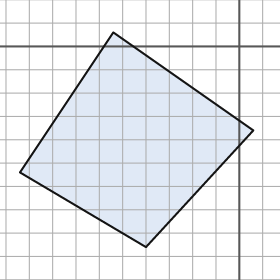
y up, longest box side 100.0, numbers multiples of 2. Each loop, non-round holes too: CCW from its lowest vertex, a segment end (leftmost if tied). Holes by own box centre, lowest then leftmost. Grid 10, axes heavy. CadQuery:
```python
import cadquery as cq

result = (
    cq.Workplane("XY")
    .moveTo(-40.0, -86.0)
    .lineTo(6.0, -36.0)
    .lineTo(-54.0, 6.0)
    .lineTo(-94.0, -54.0)
    .close()
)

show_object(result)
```